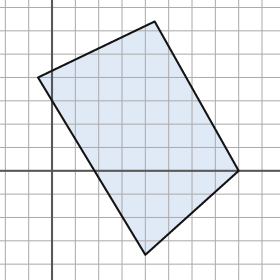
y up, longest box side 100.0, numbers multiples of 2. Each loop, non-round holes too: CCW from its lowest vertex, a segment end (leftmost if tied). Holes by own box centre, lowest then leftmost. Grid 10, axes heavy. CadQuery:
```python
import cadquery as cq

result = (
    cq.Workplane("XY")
    .moveTo(40.0, -36.0)
    .lineTo(80.0, 0.0)
    .lineTo(44.0, 64.0)
    .lineTo(-6.0, 40.0)
    .close()
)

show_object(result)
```